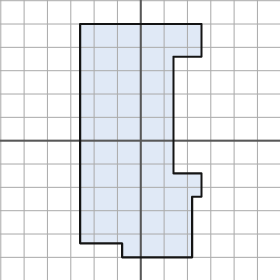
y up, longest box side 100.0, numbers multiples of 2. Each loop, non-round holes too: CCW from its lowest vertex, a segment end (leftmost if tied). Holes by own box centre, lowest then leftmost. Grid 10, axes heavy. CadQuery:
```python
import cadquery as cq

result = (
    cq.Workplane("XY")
    .moveTo(-8.0, -50.0)
    .lineTo(22.0, -50.0)
    .lineTo(22.0, -24.0)
    .lineTo(26.0, -24.0)
    .lineTo(26.0, -14.0)
    .lineTo(14.0, -14.0)
    .lineTo(14.0, 36.0)
    .lineTo(26.0, 36.0)
    .lineTo(26.0, 50.0)
    .lineTo(-26.0, 50.0)
    .lineTo(-26.0, -44.0)
    .lineTo(-8.0, -44.0)
    .close()
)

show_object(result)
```